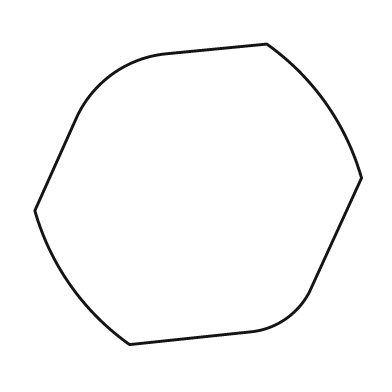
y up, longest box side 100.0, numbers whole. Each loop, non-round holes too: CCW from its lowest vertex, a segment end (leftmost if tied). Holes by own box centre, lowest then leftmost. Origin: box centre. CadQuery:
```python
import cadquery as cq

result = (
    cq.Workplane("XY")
    .moveTo(-21.0, -46.0)
    .lineTo(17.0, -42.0)
    .threePointArc((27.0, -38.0), (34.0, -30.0))
    .lineTo(50.0, 5.0)
    .threePointArc((39.0, 28.0), (21.0, 46.0))
    .lineTo(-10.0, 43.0)
    .threePointArc((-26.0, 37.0), (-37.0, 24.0))
    .lineTo(-50.0, -5.0)
    .threePointArc((-39.0, -28.0), (-21.0, -46.0))
    .close()
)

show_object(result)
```